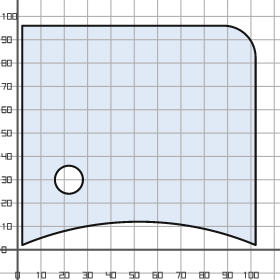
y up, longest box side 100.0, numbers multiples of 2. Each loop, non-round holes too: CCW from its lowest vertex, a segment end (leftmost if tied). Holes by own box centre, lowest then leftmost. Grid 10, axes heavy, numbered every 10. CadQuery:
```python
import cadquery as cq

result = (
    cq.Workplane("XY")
    .moveTo(2.0, 2.0)
    .threePointArc((52.0, 12.0), (102.0, 2.0))
    .lineTo(102.0, 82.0)
    .threePointArc((98.0, 92.0), (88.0, 96.0))
    .lineTo(2.0, 96.0)
    .close()
    .moveTo(22.0, 30.0)
    .circle(6.0)
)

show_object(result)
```